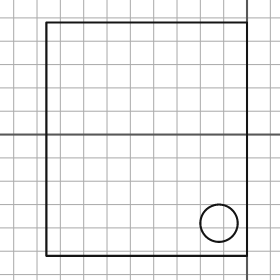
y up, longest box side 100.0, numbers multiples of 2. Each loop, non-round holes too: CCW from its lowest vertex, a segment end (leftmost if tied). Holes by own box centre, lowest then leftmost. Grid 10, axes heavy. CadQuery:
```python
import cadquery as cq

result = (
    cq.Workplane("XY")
    .moveTo(-86.0, -52.0)
    .lineTo(0.0, -52.0)
    .lineTo(0.0, 48.0)
    .lineTo(-86.0, 48.0)
    .close()
    .moveTo(-12.0, -38.0)
    .circle(8.0)
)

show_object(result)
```